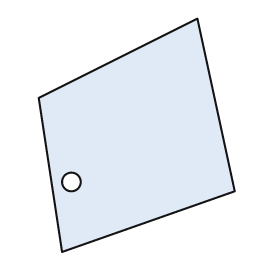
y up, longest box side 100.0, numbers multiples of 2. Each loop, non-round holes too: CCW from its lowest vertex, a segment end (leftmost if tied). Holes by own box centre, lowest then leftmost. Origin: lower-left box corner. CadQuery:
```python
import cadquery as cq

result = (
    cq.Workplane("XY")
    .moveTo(10.0, 0.0)
    .lineTo(84.0, 26.0)
    .lineTo(68.0, 100.0)
    .lineTo(0.0, 66.0)
    .close()
    .moveTo(14.0, 30.0)
    .circle(4.0)
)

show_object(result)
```